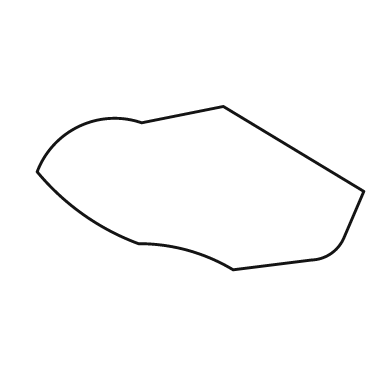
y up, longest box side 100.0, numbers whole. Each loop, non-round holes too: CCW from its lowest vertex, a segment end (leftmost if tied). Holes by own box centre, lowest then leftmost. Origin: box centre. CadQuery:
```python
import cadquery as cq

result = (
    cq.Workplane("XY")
    .moveTo(10.0, -25.0)
    .lineTo(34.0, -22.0)
    .threePointArc((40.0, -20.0), (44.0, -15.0))
    .lineTo(50.0, -1.0)
    .lineTo(7.0, 25.0)
    .lineTo(-18.0, 20.0)
    .threePointArc((-37.0, 19.0), (-50.0, 5.0))
    .threePointArc((-36.0, -8.0), (-19.0, -17.0))
    .threePointArc((-4.0, -19.0), (10.0, -25.0))
    .close()
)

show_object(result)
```